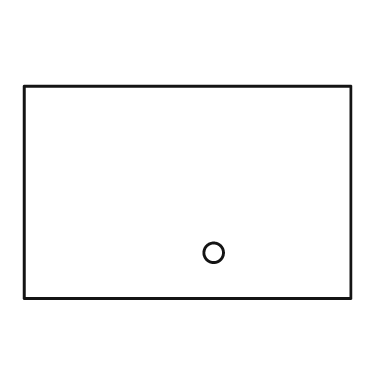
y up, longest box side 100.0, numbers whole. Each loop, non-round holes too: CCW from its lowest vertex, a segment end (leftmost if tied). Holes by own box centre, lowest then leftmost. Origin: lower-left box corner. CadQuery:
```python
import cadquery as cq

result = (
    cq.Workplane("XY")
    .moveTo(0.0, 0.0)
    .lineTo(100.0, 0.0)
    .lineTo(100.0, 65.0)
    .lineTo(0.0, 65.0)
    .close()
    .moveTo(58.0, 14.0)
    .circle(3.0)
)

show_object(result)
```